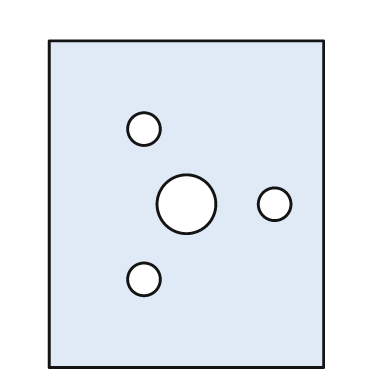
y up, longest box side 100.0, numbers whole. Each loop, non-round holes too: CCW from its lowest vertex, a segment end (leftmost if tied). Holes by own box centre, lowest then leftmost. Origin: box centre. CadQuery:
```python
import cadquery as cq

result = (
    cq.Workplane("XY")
    .moveTo(-42.0, -50.0)
    .lineTo(42.0, -50.0)
    .lineTo(42.0, 50.0)
    .lineTo(-42.0, 50.0)
    .close()
    .moveTo(-13.0, -23.0)
    .circle(5.0)
    .moveTo(0.0, 0.0)
    .circle(9.0)
    .moveTo(27.0, 0.0)
    .circle(5.0)
    .moveTo(-13.0, 23.0)
    .circle(5.0)
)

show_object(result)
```